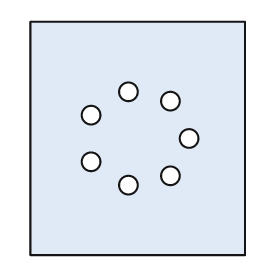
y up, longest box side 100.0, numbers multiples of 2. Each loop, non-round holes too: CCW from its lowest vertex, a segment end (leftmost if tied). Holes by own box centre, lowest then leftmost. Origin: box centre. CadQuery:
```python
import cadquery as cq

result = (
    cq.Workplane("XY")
    .moveTo(-46.0, -50.0)
    .lineTo(46.0, -50.0)
    .lineTo(46.0, 50.0)
    .lineTo(-46.0, 50.0)
    .close()
    .moveTo(-4.0, -20.0)
    .circle(4.0)
    .moveTo(14.0, -16.0)
    .circle(4.0)
    .moveTo(-20.0, -10.0)
    .circle(4.0)
    .moveTo(22.0, 0.0)
    .circle(4.0)
    .moveTo(-20.0, 10.0)
    .circle(4.0)
    .moveTo(14.0, 16.0)
    .circle(4.0)
    .moveTo(-4.0, 20.0)
    .circle(4.0)
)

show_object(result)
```